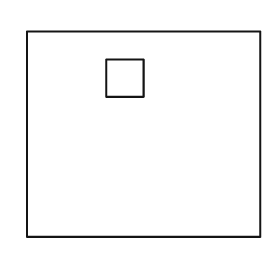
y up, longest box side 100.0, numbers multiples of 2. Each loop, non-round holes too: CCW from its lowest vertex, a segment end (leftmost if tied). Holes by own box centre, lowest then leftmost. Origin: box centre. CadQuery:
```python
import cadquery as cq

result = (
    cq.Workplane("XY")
    .moveTo(-50.0, -44.0)
    .lineTo(50.0, -44.0)
    .lineTo(50.0, 44.0)
    .lineTo(-50.0, 44.0)
    .close()
    .moveTo(-16.0, 16.0)
    .lineTo(0.0, 16.0)
    .lineTo(0.0, 32.0)
    .lineTo(-16.0, 32.0)
    .close()
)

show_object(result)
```